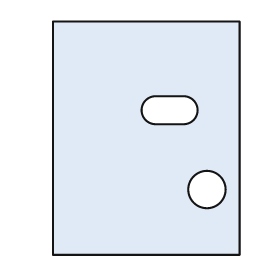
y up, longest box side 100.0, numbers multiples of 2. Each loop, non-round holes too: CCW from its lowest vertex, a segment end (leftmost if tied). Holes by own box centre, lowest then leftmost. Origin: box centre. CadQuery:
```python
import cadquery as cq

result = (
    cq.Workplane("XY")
    .moveTo(-40.0, -50.0)
    .lineTo(40.0, -50.0)
    .lineTo(40.0, 50.0)
    .lineTo(-40.0, 50.0)
    .close()
    .moveTo(26.0, -22.0)
    .circle(8.0)
    .moveTo(4.0, 6.0)
    .lineTo(16.0, 6.0)
    .threePointArc((22.0, 12.0), (16.0, 18.0))
    .lineTo(4.0, 18.0)
    .threePointArc((-2.0, 12.0), (4.0, 6.0))
    .close()
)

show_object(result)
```